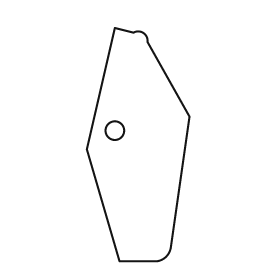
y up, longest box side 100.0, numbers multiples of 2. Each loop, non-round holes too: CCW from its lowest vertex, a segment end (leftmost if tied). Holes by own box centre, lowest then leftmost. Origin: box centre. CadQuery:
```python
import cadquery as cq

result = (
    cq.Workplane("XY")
    .moveTo(-8.0, -50.0)
    .lineTo(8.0, -50.0)
    .threePointArc((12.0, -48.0), (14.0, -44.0))
    .lineTo(22.0, 12.0)
    .lineTo(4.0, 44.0)
    .threePointArc((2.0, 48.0), (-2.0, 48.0))
    .lineTo(-10.0, 50.0)
    .lineTo(-22.0, -2.0)
    .close()
    .moveTo(-10.0, 6.0)
    .circle(4.0)
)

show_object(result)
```